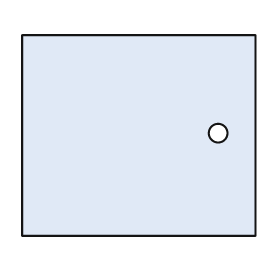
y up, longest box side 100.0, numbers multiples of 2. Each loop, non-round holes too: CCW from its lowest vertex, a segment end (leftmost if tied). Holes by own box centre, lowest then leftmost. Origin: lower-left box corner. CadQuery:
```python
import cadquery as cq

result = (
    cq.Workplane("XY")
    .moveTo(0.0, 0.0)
    .lineTo(100.0, 0.0)
    .lineTo(100.0, 86.0)
    .lineTo(0.0, 86.0)
    .close()
    .moveTo(84.0, 44.0)
    .circle(4.0)
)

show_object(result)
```